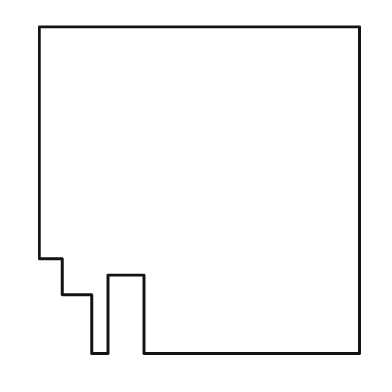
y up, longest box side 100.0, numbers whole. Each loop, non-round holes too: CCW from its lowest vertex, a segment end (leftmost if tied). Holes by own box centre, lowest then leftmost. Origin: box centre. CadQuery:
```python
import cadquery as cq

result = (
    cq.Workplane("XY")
    .moveTo(-33.0, -50.0)
    .lineTo(-28.0, -50.0)
    .lineTo(-28.0, -26.0)
    .lineTo(-17.0, -26.0)
    .lineTo(-17.0, -50.0)
    .lineTo(49.0, -50.0)
    .lineTo(49.0, 50.0)
    .lineTo(-49.0, 50.0)
    .lineTo(-49.0, -21.0)
    .lineTo(-42.0, -21.0)
    .lineTo(-42.0, -32.0)
    .lineTo(-33.0, -32.0)
    .close()
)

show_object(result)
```